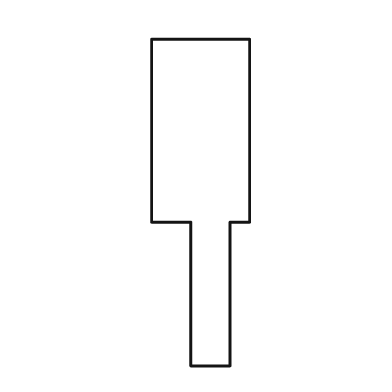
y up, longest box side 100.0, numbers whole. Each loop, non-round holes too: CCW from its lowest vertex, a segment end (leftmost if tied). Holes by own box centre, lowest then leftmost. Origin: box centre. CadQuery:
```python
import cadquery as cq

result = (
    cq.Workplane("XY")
    .moveTo(-3.0, -50.0)
    .lineTo(9.0, -50.0)
    .lineTo(9.0, -6.0)
    .lineTo(15.0, -6.0)
    .lineTo(15.0, 50.0)
    .lineTo(-15.0, 50.0)
    .lineTo(-15.0, -6.0)
    .lineTo(-3.0, -6.0)
    .close()
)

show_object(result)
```